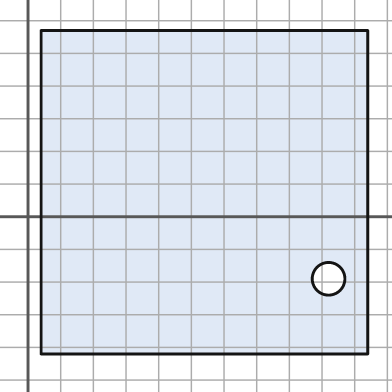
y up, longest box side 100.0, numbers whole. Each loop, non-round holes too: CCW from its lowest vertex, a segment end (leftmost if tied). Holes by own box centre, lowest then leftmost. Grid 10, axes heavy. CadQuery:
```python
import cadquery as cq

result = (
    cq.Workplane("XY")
    .moveTo(4.0, -42.0)
    .lineTo(104.0, -42.0)
    .lineTo(104.0, 57.0)
    .lineTo(4.0, 57.0)
    .close()
    .moveTo(92.0, -19.0)
    .circle(5.0)
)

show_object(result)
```